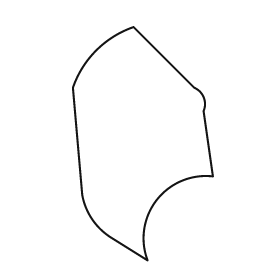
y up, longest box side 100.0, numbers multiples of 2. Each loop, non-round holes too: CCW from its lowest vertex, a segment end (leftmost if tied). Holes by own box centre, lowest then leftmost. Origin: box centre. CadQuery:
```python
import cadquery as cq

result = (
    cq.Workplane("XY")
    .moveTo(2.0, -50.0)
    .threePointArc((6.0, -24.0), (30.0, -14.0))
    .lineTo(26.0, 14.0)
    .threePointArc((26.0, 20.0), (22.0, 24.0))
    .lineTo(-4.0, 50.0)
    .threePointArc((-20.0, 40.0), (-30.0, 24.0))
    .lineTo(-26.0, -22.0)
    .threePointArc((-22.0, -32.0), (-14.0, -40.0))
    .close()
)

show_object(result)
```